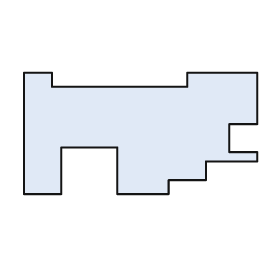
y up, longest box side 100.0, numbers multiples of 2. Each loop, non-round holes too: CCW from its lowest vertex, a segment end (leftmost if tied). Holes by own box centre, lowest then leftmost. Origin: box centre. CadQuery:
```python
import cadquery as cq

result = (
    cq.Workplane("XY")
    .moveTo(-50.0, -26.0)
    .lineTo(-34.0, -26.0)
    .lineTo(-34.0, -6.0)
    .lineTo(-10.0, -6.0)
    .lineTo(-10.0, -26.0)
    .lineTo(12.0, -26.0)
    .lineTo(12.0, -20.0)
    .lineTo(28.0, -20.0)
    .lineTo(28.0, -12.0)
    .lineTo(50.0, -12.0)
    .lineTo(50.0, -8.0)
    .lineTo(38.0, -8.0)
    .lineTo(38.0, 4.0)
    .lineTo(50.0, 4.0)
    .lineTo(50.0, 26.0)
    .lineTo(20.0, 26.0)
    .lineTo(20.0, 20.0)
    .lineTo(-38.0, 20.0)
    .lineTo(-38.0, 26.0)
    .lineTo(-50.0, 26.0)
    .close()
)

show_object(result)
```